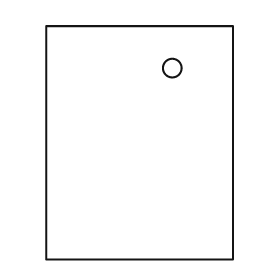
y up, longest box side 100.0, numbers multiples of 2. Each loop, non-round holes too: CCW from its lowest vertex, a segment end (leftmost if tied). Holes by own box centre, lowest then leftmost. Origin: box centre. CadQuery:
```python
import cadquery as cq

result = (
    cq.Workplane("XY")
    .moveTo(-40.0, -50.0)
    .lineTo(40.0, -50.0)
    .lineTo(40.0, 50.0)
    .lineTo(-40.0, 50.0)
    .close()
    .moveTo(14.0, 32.0)
    .circle(4.0)
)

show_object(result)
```